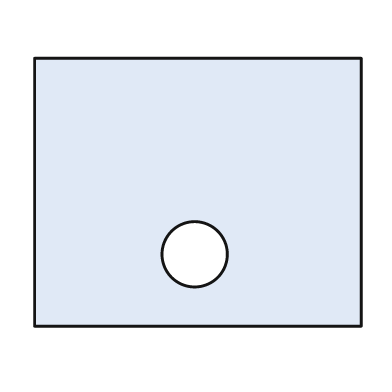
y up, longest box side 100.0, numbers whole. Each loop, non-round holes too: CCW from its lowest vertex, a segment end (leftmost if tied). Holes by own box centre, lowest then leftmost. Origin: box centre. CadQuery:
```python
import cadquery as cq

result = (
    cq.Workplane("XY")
    .moveTo(-50.0, -41.0)
    .lineTo(50.0, -41.0)
    .lineTo(50.0, 41.0)
    .lineTo(-50.0, 41.0)
    .close()
    .moveTo(-1.0, -19.0)
    .circle(10.0)
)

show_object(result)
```